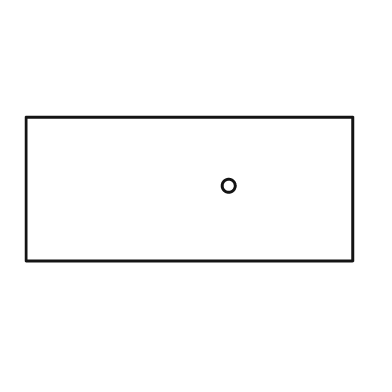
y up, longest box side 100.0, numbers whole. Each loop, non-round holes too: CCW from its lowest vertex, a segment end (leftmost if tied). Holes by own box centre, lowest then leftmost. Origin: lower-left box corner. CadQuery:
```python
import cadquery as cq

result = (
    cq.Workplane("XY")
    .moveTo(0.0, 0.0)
    .lineTo(100.0, 0.0)
    .lineTo(100.0, 44.0)
    .lineTo(0.0, 44.0)
    .close()
    .moveTo(62.0, 23.0)
    .circle(2.0)
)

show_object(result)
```